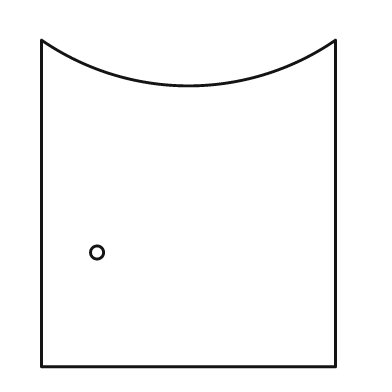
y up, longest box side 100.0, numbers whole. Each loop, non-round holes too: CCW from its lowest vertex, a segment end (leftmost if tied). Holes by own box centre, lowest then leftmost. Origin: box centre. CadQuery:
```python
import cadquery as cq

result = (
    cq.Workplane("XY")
    .moveTo(-45.0, -50.0)
    .lineTo(45.0, -50.0)
    .lineTo(45.0, 50.0)
    .threePointArc((0.0, 36.0), (-45.0, 50.0))
    .close()
    .moveTo(-28.0, -15.0)
    .circle(2.0)
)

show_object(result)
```